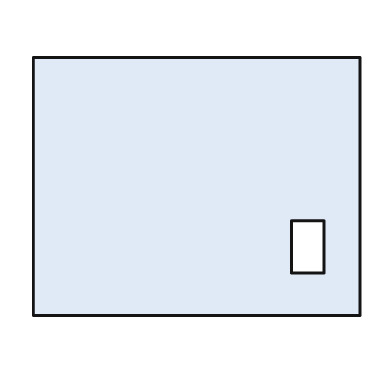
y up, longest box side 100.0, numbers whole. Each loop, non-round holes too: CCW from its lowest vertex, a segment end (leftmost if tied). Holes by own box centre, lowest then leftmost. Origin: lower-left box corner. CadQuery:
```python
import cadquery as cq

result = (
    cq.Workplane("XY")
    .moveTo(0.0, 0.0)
    .lineTo(100.0, 0.0)
    .lineTo(100.0, 79.0)
    .lineTo(0.0, 79.0)
    .close()
    .moveTo(79.0, 13.0)
    .lineTo(89.0, 13.0)
    .lineTo(89.0, 29.0)
    .lineTo(79.0, 29.0)
    .close()
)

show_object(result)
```